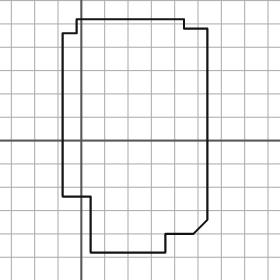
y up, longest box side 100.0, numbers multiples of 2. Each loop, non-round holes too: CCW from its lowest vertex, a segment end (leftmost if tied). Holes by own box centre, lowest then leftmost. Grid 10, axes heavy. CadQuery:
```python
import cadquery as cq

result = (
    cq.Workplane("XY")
    .moveTo(4.0, -48.0)
    .lineTo(36.0, -48.0)
    .lineTo(36.0, -40.0)
    .lineTo(48.0, -40.0)
    .lineTo(54.0, -34.0)
    .lineTo(54.0, 48.0)
    .lineTo(44.0, 48.0)
    .lineTo(44.0, 52.0)
    .lineTo(-2.0, 52.0)
    .lineTo(-2.0, 46.0)
    .lineTo(-8.0, 46.0)
    .lineTo(-8.0, -24.0)
    .lineTo(4.0, -24.0)
    .close()
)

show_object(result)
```